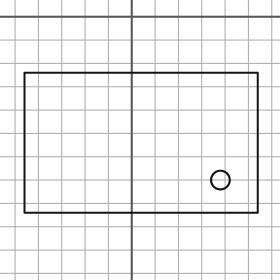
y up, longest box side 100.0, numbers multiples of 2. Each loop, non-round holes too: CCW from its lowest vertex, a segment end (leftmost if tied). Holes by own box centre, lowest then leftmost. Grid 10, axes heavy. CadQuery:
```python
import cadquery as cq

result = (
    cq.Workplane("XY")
    .moveTo(-46.0, -84.0)
    .lineTo(54.0, -84.0)
    .lineTo(54.0, -24.0)
    .lineTo(-46.0, -24.0)
    .close()
    .moveTo(38.0, -70.0)
    .circle(4.0)
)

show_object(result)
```